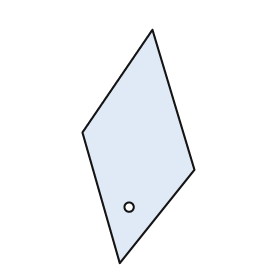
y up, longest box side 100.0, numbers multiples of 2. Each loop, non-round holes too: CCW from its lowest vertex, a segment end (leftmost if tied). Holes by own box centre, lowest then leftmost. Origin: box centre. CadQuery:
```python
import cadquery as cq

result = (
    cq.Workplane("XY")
    .moveTo(-8.0, -50.0)
    .lineTo(24.0, -10.0)
    .lineTo(6.0, 50.0)
    .lineTo(-24.0, 6.0)
    .close()
    .moveTo(-4.0, -26.0)
    .circle(2.0)
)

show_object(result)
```